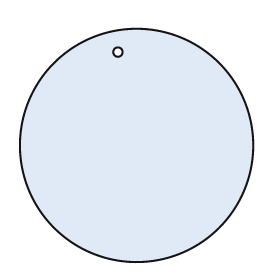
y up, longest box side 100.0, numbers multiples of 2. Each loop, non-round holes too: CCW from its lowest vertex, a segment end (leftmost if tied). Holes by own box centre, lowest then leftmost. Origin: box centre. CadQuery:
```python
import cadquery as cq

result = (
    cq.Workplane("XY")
    .moveTo(0.0, 0.0)
    .circle(50.0)
    .moveTo(-8.0, 40.0)
    .circle(2.0)
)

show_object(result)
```